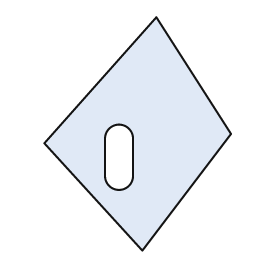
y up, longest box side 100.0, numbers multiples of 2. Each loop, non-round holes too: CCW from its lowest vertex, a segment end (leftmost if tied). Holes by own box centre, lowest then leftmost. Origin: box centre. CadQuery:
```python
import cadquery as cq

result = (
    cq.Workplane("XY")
    .moveTo(2.0, -50.0)
    .lineTo(40.0, 0.0)
    .lineTo(8.0, 50.0)
    .lineTo(-40.0, -4.0)
    .close()
    .moveTo(-14.0, -18.0)
    .threePointArc((-8.0, -24.0), (-2.0, -18.0))
    .lineTo(-2.0, -2.0)
    .threePointArc((-8.0, 4.0), (-14.0, -2.0))
    .close()
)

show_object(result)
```